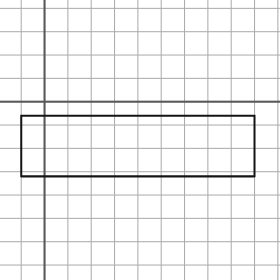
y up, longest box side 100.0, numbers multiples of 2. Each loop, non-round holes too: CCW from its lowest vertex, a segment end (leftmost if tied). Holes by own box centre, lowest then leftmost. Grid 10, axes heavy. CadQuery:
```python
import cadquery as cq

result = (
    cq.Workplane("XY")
    .moveTo(-10.0, -32.0)
    .lineTo(90.0, -32.0)
    .lineTo(90.0, -6.0)
    .lineTo(-10.0, -6.0)
    .close()
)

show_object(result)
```